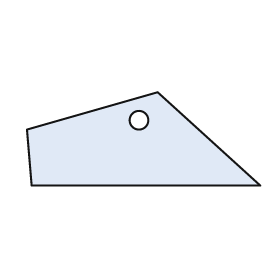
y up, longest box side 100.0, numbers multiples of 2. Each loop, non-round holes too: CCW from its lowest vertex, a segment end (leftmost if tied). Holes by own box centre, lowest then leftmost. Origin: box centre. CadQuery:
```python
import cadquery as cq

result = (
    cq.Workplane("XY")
    .moveTo(-48.0, -20.0)
    .lineTo(50.0, -20.0)
    .lineTo(6.0, 20.0)
    .lineTo(-50.0, 4.0)
    .close()
    .moveTo(-2.0, 8.0)
    .circle(4.0)
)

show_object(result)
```